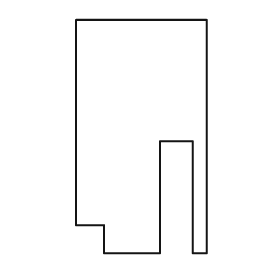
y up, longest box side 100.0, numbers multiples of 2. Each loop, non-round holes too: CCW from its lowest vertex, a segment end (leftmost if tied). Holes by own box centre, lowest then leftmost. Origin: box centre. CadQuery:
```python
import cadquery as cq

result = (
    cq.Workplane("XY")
    .moveTo(-16.0, -50.0)
    .lineTo(8.0, -50.0)
    .lineTo(8.0, -2.0)
    .lineTo(22.0, -2.0)
    .lineTo(22.0, -50.0)
    .lineTo(28.0, -50.0)
    .lineTo(28.0, 50.0)
    .lineTo(-28.0, 50.0)
    .lineTo(-28.0, -38.0)
    .lineTo(-16.0, -38.0)
    .close()
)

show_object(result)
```